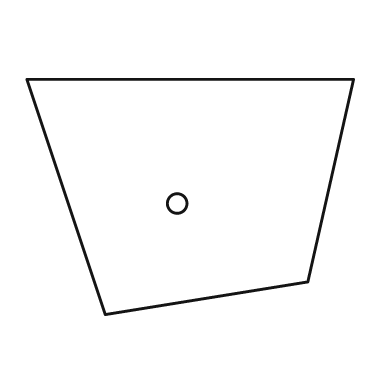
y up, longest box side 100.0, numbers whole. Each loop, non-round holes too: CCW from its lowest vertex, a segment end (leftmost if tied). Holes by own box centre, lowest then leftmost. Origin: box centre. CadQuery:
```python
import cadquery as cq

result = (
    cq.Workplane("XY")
    .moveTo(-26.0, -36.0)
    .lineTo(36.0, -26.0)
    .lineTo(50.0, 36.0)
    .lineTo(-50.0, 36.0)
    .close()
    .moveTo(-4.0, -2.0)
    .circle(3.0)
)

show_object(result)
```